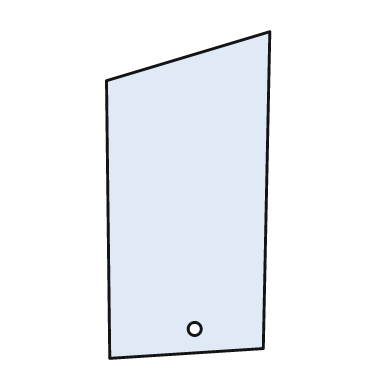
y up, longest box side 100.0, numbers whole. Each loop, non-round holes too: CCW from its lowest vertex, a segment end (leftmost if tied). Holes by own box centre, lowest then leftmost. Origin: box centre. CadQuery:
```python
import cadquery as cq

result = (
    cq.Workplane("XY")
    .moveTo(-24.0, -50.0)
    .lineTo(23.0, -47.0)
    .lineTo(25.0, 50.0)
    .lineTo(-25.0, 35.0)
    .close()
    .moveTo(2.0, -41.0)
    .circle(2.0)
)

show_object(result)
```